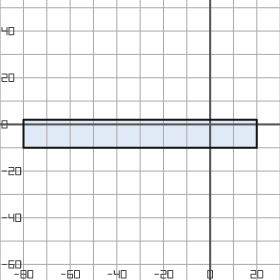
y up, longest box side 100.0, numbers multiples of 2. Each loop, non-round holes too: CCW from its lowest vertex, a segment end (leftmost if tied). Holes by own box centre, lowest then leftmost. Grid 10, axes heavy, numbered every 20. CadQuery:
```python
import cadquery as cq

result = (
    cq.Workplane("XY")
    .moveTo(-80.0, -10.0)
    .lineTo(20.0, -10.0)
    .lineTo(20.0, 2.0)
    .lineTo(-80.0, 2.0)
    .close()
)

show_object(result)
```